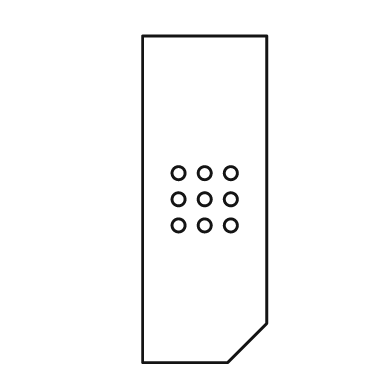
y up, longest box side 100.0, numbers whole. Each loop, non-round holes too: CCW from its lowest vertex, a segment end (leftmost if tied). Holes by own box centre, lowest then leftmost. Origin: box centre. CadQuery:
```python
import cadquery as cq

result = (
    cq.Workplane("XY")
    .moveTo(-19.0, -50.0)
    .lineTo(7.0, -50.0)
    .lineTo(19.0, -38.0)
    .lineTo(19.0, 50.0)
    .lineTo(-19.0, 50.0)
    .close()
    .moveTo(-8.0, -8.0)
    .circle(2.0)
    .moveTo(0.0, -8.0)
    .circle(2.0)
    .moveTo(8.0, -8.0)
    .circle(2.0)
    .moveTo(-8.0, 0.0)
    .circle(2.0)
    .moveTo(0.0, 0.0)
    .circle(2.0)
    .moveTo(8.0, 0.0)
    .circle(2.0)
    .moveTo(-8.0, 8.0)
    .circle(2.0)
    .moveTo(0.0, 8.0)
    .circle(2.0)
    .moveTo(8.0, 8.0)
    .circle(2.0)
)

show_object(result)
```